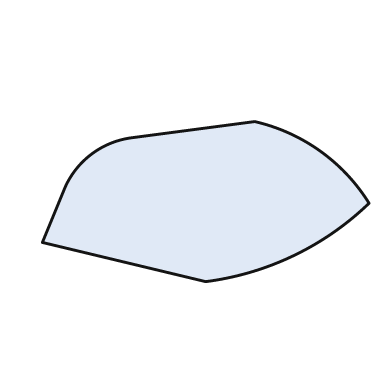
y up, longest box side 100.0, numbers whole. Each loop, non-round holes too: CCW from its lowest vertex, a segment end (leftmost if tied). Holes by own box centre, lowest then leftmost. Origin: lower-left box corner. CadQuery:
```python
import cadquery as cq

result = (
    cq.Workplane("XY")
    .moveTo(50.0, 0.0)
    .threePointArc((77.0, 8.0), (100.0, 24.0))
    .threePointArc((85.0, 40.0), (65.0, 49.0))
    .lineTo(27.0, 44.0)
    .threePointArc((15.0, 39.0), (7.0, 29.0))
    .lineTo(0.0, 12.0)
    .close()
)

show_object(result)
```